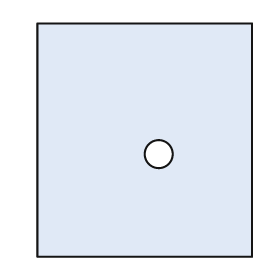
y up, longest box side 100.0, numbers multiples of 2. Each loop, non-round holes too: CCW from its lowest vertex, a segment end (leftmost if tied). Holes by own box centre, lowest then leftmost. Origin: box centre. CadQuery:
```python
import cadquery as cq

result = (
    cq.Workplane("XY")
    .moveTo(-46.0, -50.0)
    .lineTo(46.0, -50.0)
    .lineTo(46.0, 50.0)
    .lineTo(-46.0, 50.0)
    .close()
    .moveTo(6.0, -6.0)
    .circle(6.0)
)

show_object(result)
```